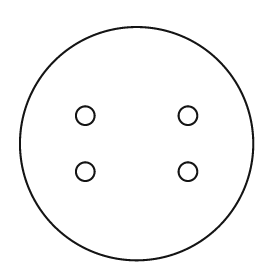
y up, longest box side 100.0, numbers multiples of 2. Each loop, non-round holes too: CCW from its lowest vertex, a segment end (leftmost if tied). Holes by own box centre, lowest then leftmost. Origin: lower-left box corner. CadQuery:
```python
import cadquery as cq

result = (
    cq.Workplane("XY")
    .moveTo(50.0, 50.0)
    .circle(50.0)
    .moveTo(28.0, 38.0)
    .circle(4.0)
    .moveTo(72.0, 38.0)
    .circle(4.0)
    .moveTo(28.0, 62.0)
    .circle(4.0)
    .moveTo(72.0, 62.0)
    .circle(4.0)
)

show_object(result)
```